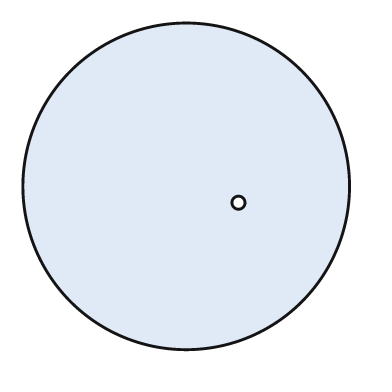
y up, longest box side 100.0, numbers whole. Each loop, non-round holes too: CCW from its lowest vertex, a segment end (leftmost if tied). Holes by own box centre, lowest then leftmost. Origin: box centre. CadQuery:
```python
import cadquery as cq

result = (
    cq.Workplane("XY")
    .moveTo(0.0, 0.0)
    .circle(50.0)
    .moveTo(16.0, -5.0)
    .circle(2.0)
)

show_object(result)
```